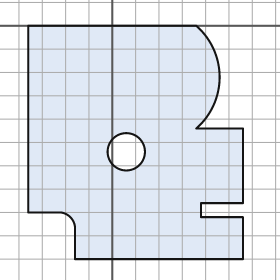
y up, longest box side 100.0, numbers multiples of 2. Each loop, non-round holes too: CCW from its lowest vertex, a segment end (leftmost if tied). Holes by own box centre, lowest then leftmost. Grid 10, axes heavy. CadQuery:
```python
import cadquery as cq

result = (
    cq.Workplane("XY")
    .moveTo(-16.0, -100.0)
    .lineTo(56.0, -100.0)
    .lineTo(56.0, -82.0)
    .lineTo(38.0, -82.0)
    .lineTo(38.0, -76.0)
    .lineTo(56.0, -76.0)
    .lineTo(56.0, -44.0)
    .lineTo(36.0, -44.0)
    .threePointArc((46.0, -22.0), (36.0, 0.0))
    .lineTo(-36.0, 0.0)
    .lineTo(-36.0, -80.0)
    .lineTo(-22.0, -80.0)
    .threePointArc((-18.0, -82.0), (-16.0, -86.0))
    .close()
    .moveTo(6.0, -54.0)
    .circle(8.0)
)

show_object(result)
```